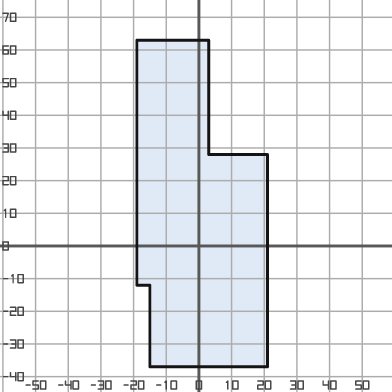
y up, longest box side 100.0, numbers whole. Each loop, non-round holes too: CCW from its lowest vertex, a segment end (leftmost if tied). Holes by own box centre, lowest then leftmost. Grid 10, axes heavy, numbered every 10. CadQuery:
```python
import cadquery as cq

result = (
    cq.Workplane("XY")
    .moveTo(-15.0, -37.0)
    .lineTo(21.0, -37.0)
    .lineTo(21.0, 28.0)
    .lineTo(3.0, 28.0)
    .lineTo(3.0, 63.0)
    .lineTo(-19.0, 63.0)
    .lineTo(-19.0, -12.0)
    .lineTo(-15.0, -12.0)
    .close()
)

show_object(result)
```